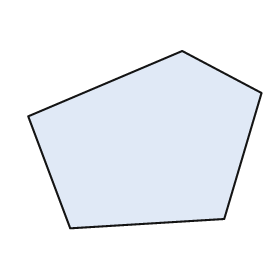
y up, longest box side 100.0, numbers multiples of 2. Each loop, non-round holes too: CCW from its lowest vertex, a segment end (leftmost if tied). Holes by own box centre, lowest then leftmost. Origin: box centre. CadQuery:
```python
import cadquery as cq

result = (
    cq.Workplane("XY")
    .moveTo(-32.0, -38.0)
    .lineTo(34.0, -34.0)
    .lineTo(50.0, 20.0)
    .lineTo(16.0, 38.0)
    .lineTo(-50.0, 10.0)
    .close()
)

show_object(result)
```